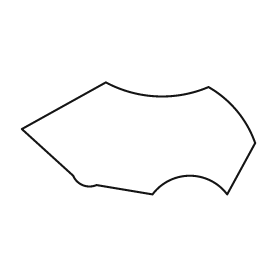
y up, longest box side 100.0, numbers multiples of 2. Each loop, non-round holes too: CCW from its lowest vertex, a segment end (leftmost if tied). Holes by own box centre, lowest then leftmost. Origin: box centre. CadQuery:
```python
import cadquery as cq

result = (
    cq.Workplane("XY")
    .moveTo(6.0, -24.0)
    .threePointArc((22.0, -16.0), (38.0, -24.0))
    .lineTo(50.0, -2.0)
    .threePointArc((42.0, 12.0), (30.0, 22.0))
    .threePointArc((8.0, 18.0), (-14.0, 24.0))
    .lineTo(-50.0, 4.0)
    .lineTo(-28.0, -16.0)
    .threePointArc((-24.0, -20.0), (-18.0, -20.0))
    .close()
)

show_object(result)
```